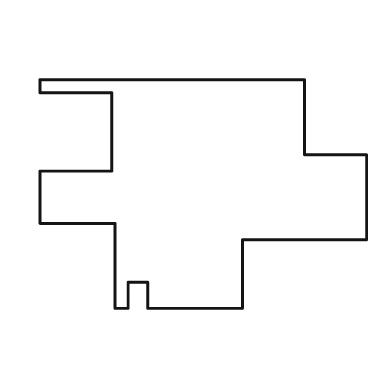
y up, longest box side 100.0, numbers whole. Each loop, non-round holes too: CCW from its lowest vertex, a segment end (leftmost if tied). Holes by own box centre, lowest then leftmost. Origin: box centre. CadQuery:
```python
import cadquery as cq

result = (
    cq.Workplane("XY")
    .moveTo(-27.0, -35.0)
    .lineTo(-23.0, -35.0)
    .lineTo(-23.0, -27.0)
    .lineTo(-17.0, -27.0)
    .lineTo(-17.0, -35.0)
    .lineTo(12.0, -35.0)
    .lineTo(12.0, -14.0)
    .lineTo(50.0, -14.0)
    .lineTo(50.0, 12.0)
    .lineTo(31.0, 12.0)
    .lineTo(31.0, 35.0)
    .lineTo(-50.0, 35.0)
    .lineTo(-50.0, 31.0)
    .lineTo(-28.0, 31.0)
    .lineTo(-28.0, 7.0)
    .lineTo(-50.0, 7.0)
    .lineTo(-50.0, -9.0)
    .lineTo(-27.0, -9.0)
    .close()
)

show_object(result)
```